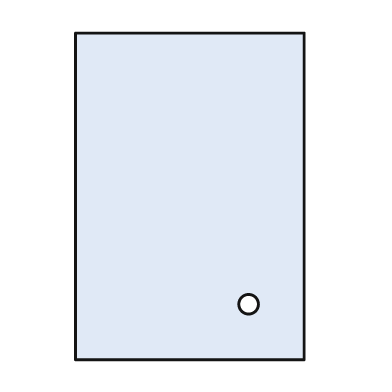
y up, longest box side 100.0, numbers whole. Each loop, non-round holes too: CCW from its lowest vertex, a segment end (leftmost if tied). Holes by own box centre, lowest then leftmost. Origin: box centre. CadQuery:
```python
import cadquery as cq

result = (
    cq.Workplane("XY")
    .moveTo(-35.0, -50.0)
    .lineTo(35.0, -50.0)
    .lineTo(35.0, 50.0)
    .lineTo(-35.0, 50.0)
    .close()
    .moveTo(18.0, -33.0)
    .circle(3.0)
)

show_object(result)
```